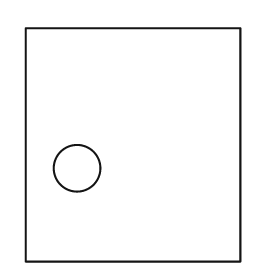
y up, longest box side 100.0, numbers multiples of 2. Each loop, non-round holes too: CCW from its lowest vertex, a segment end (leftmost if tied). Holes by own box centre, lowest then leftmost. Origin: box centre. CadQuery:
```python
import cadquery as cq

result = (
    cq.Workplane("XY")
    .moveTo(-46.0, -50.0)
    .lineTo(46.0, -50.0)
    .lineTo(46.0, 50.0)
    .lineTo(-46.0, 50.0)
    .close()
    .moveTo(-24.0, -10.0)
    .circle(10.0)
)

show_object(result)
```